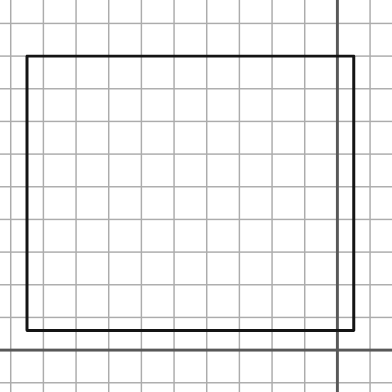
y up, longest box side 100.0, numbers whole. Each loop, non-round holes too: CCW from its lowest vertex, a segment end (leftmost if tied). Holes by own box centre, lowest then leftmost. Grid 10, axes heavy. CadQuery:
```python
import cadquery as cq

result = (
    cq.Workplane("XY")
    .moveTo(-95.0, 6.0)
    .lineTo(5.0, 6.0)
    .lineTo(5.0, 90.0)
    .lineTo(-95.0, 90.0)
    .close()
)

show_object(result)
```